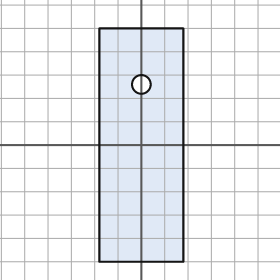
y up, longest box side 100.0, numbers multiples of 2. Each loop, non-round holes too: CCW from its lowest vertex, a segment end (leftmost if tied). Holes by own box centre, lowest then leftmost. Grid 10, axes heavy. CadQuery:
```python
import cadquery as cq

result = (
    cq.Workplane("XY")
    .moveTo(-18.0, -50.0)
    .lineTo(18.0, -50.0)
    .lineTo(18.0, 50.0)
    .lineTo(-18.0, 50.0)
    .close()
    .moveTo(0.0, 26.0)
    .circle(4.0)
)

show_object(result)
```